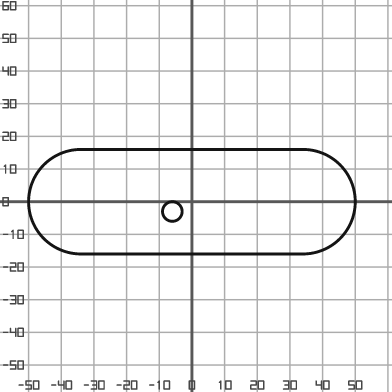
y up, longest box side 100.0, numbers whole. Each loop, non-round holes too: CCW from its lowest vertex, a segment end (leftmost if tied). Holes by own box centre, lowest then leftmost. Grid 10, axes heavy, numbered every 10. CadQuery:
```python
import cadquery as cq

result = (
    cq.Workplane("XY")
    .moveTo(-34.0, -16.0)
    .lineTo(34.0, -16.0)
    .threePointArc((50.0, 0.0), (34.0, 16.0))
    .lineTo(-34.0, 16.0)
    .threePointArc((-50.0, 0.0), (-34.0, -16.0))
    .close()
    .moveTo(-6.0, -3.0)
    .circle(3.0)
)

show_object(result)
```